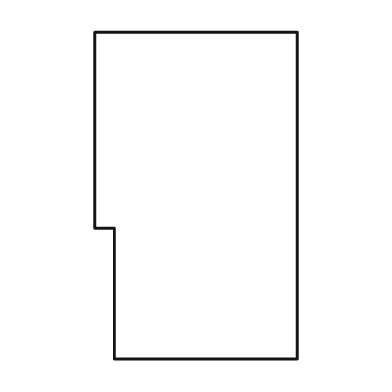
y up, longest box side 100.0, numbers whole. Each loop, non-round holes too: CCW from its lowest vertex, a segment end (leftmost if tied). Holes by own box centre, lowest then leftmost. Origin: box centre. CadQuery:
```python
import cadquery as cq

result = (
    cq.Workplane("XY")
    .moveTo(-25.0, -50.0)
    .lineTo(31.0, -50.0)
    .lineTo(31.0, 50.0)
    .lineTo(-31.0, 50.0)
    .lineTo(-31.0, -10.0)
    .lineTo(-25.0, -10.0)
    .close()
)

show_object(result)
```